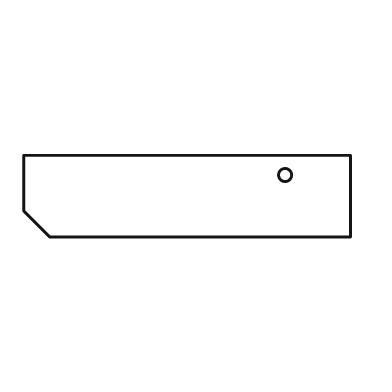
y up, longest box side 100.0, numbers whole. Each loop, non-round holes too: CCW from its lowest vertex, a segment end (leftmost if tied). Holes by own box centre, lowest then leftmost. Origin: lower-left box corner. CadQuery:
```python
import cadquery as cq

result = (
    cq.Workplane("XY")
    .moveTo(8.0, 0.0)
    .lineTo(100.0, 0.0)
    .lineTo(100.0, 25.0)
    .lineTo(0.0, 25.0)
    .lineTo(0.0, 8.0)
    .close()
    .moveTo(80.0, 19.0)
    .circle(2.0)
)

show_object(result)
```